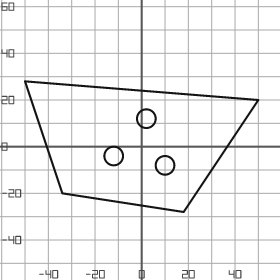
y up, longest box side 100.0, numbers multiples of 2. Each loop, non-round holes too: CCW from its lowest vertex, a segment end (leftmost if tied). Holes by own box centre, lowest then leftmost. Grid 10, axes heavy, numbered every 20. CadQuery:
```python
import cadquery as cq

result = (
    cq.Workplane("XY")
    .moveTo(18.0, -28.0)
    .lineTo(50.0, 20.0)
    .lineTo(-50.0, 28.0)
    .lineTo(-34.0, -20.0)
    .close()
    .moveTo(10.0, -8.0)
    .circle(4.0)
    .moveTo(-12.0, -4.0)
    .circle(4.0)
    .moveTo(2.0, 12.0)
    .circle(4.0)
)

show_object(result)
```